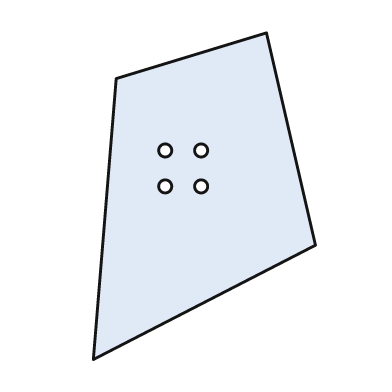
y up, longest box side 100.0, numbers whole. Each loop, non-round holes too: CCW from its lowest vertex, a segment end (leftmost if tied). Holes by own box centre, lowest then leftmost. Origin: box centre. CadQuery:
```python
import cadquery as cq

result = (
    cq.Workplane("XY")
    .moveTo(-34.0, -50.0)
    .lineTo(34.0, -15.0)
    .lineTo(19.0, 50.0)
    .lineTo(-27.0, 36.0)
    .close()
    .moveTo(-12.0, 3.0)
    .circle(2.0)
    .moveTo(-1.0, 3.0)
    .circle(2.0)
    .moveTo(-12.0, 14.0)
    .circle(2.0)
    .moveTo(-1.0, 14.0)
    .circle(2.0)
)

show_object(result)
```